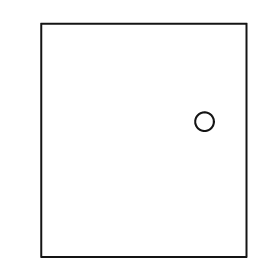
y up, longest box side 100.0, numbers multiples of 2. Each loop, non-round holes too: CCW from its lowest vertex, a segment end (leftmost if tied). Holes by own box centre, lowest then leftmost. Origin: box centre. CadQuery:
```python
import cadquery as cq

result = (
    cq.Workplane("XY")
    .moveTo(-44.0, -50.0)
    .lineTo(44.0, -50.0)
    .lineTo(44.0, 50.0)
    .lineTo(-44.0, 50.0)
    .close()
    .moveTo(26.0, 8.0)
    .circle(4.0)
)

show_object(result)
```